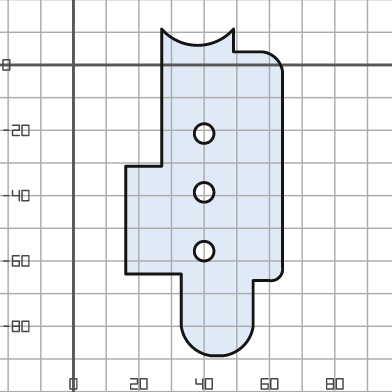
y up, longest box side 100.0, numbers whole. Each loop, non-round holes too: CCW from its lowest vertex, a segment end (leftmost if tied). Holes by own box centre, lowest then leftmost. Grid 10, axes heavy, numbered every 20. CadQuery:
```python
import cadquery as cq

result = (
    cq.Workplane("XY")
    .moveTo(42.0, -89.0)
    .lineTo(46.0, -89.0)
    .threePointArc((52.0, -86.0), (55.0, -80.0))
    .lineTo(55.0, -66.0)
    .lineTo(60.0, -66.0)
    .threePointArc((63.0, -65.0), (64.0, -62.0))
    .lineTo(64.0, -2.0)
    .threePointArc((62.0, 2.0), (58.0, 4.0))
    .lineTo(49.0, 4.0)
    .lineTo(49.0, 11.0)
    .threePointArc((38.0, 6.0), (27.0, 11.0))
    .lineTo(27.0, -31.0)
    .lineTo(16.0, -31.0)
    .lineTo(16.0, -64.0)
    .lineTo(33.0, -64.0)
    .lineTo(33.0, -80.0)
    .threePointArc((36.0, -86.0), (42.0, -89.0))
    .close()
    .moveTo(40.0, -57.0)
    .circle(3.0)
    .moveTo(40.0, -39.0)
    .circle(3.0)
    .moveTo(40.0, -21.0)
    .circle(3.0)
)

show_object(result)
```